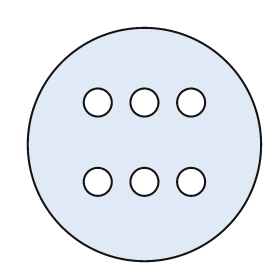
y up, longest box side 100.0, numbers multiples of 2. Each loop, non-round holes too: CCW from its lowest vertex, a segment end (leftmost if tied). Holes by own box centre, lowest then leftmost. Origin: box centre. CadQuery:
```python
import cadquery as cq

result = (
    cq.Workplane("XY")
    .moveTo(0.0, 0.0)
    .circle(50.0)
    .moveTo(-20.0, -16.0)
    .circle(6.0)
    .moveTo(0.0, -16.0)
    .circle(6.0)
    .moveTo(20.0, -16.0)
    .circle(6.0)
    .moveTo(-20.0, 18.0)
    .circle(6.0)
    .moveTo(0.0, 18.0)
    .circle(6.0)
    .moveTo(20.0, 18.0)
    .circle(6.0)
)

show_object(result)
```